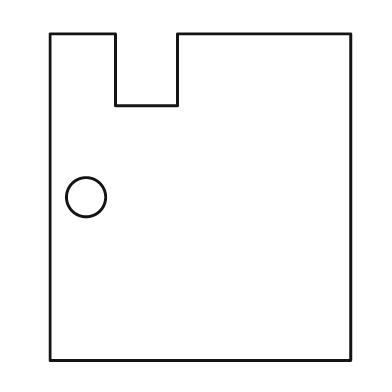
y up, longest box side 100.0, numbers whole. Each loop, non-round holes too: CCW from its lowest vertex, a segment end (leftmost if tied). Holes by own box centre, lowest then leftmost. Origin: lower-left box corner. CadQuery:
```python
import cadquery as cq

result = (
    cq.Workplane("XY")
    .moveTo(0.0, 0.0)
    .lineTo(92.0, 0.0)
    .lineTo(92.0, 100.0)
    .lineTo(39.0, 100.0)
    .lineTo(39.0, 78.0)
    .lineTo(20.0, 78.0)
    .lineTo(20.0, 100.0)
    .lineTo(0.0, 100.0)
    .close()
    .moveTo(11.0, 50.0)
    .circle(6.0)
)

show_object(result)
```